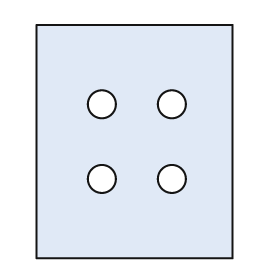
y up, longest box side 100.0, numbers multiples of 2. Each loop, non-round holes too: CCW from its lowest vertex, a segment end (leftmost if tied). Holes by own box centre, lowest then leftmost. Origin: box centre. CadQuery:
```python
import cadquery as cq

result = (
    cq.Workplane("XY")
    .moveTo(-42.0, -50.0)
    .lineTo(42.0, -50.0)
    .lineTo(42.0, 50.0)
    .lineTo(-42.0, 50.0)
    .close()
    .moveTo(-14.0, -16.0)
    .circle(6.0)
    .moveTo(16.0, -16.0)
    .circle(6.0)
    .moveTo(-14.0, 16.0)
    .circle(6.0)
    .moveTo(16.0, 16.0)
    .circle(6.0)
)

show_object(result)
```